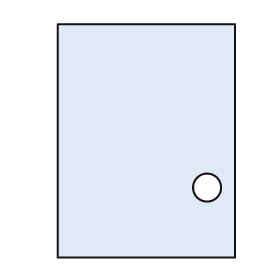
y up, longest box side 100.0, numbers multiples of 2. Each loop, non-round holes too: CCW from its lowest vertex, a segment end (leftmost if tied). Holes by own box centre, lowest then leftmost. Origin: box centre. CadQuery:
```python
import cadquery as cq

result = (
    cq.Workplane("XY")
    .moveTo(-38.0, -50.0)
    .lineTo(38.0, -50.0)
    .lineTo(38.0, 50.0)
    .lineTo(-38.0, 50.0)
    .close()
    .moveTo(26.0, -20.0)
    .circle(6.0)
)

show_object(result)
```